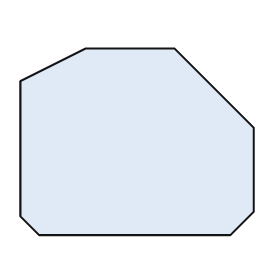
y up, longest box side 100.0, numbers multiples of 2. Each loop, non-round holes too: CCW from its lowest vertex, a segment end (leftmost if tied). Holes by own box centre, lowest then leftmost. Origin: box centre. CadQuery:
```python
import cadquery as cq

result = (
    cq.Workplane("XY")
    .moveTo(-42.0, -40.0)
    .lineTo(40.0, -40.0)
    .lineTo(50.0, -30.0)
    .lineTo(50.0, 6.0)
    .lineTo(16.0, 40.0)
    .lineTo(-22.0, 40.0)
    .lineTo(-50.0, 26.0)
    .lineTo(-50.0, -32.0)
    .close()
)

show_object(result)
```